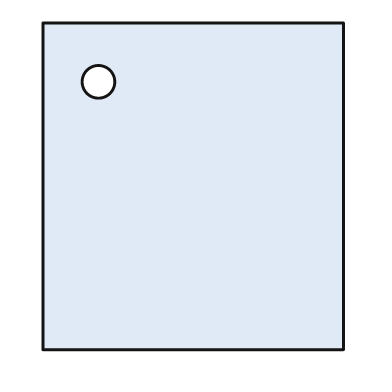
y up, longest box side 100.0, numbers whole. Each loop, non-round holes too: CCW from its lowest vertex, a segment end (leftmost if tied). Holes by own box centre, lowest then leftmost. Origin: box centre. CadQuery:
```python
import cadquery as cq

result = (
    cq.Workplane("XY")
    .moveTo(-46.0, -50.0)
    .lineTo(46.0, -50.0)
    .lineTo(46.0, 50.0)
    .lineTo(-46.0, 50.0)
    .close()
    .moveTo(-29.0, 32.0)
    .circle(5.0)
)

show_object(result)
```